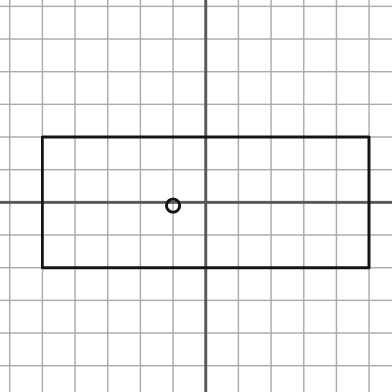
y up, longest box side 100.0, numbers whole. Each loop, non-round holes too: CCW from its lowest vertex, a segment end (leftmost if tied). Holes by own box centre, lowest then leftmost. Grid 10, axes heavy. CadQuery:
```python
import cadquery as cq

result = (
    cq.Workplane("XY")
    .moveTo(-50.0, -20.0)
    .lineTo(50.0, -20.0)
    .lineTo(50.0, 20.0)
    .lineTo(-50.0, 20.0)
    .close()
    .moveTo(-10.0, -1.0)
    .circle(2.0)
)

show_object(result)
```